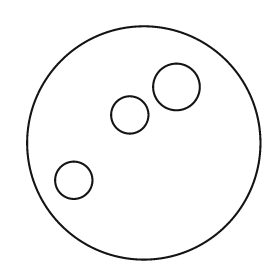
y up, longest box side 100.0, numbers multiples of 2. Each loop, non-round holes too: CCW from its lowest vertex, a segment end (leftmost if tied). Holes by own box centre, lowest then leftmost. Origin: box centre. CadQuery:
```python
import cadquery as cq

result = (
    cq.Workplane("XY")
    .moveTo(0.0, 0.0)
    .circle(50.0)
    .moveTo(-30.0, -16.0)
    .circle(8.0)
    .moveTo(-6.0, 12.0)
    .circle(8.0)
    .moveTo(14.0, 24.0)
    .circle(10.0)
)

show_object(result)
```